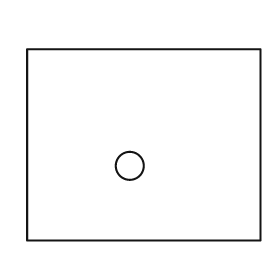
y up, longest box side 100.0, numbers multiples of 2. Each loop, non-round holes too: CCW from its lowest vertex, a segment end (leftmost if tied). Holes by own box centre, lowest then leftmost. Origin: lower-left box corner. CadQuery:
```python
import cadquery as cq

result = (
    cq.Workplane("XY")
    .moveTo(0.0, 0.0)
    .lineTo(100.0, 0.0)
    .lineTo(100.0, 82.0)
    .lineTo(0.0, 82.0)
    .close()
    .moveTo(44.0, 32.0)
    .circle(6.0)
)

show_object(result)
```